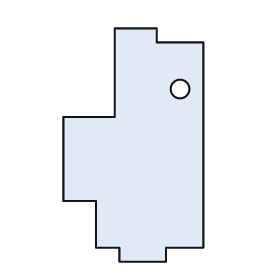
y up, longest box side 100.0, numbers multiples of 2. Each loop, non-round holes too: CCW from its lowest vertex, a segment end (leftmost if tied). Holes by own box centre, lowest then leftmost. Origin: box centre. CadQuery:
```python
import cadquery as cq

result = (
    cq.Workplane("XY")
    .moveTo(-6.0, -50.0)
    .lineTo(14.0, -50.0)
    .lineTo(14.0, -44.0)
    .lineTo(30.0, -44.0)
    .lineTo(30.0, 44.0)
    .lineTo(10.0, 44.0)
    .lineTo(10.0, 50.0)
    .lineTo(-8.0, 50.0)
    .lineTo(-8.0, 12.0)
    .lineTo(-30.0, 12.0)
    .lineTo(-30.0, -24.0)
    .lineTo(-16.0, -24.0)
    .lineTo(-16.0, -44.0)
    .lineTo(-6.0, -44.0)
    .close()
    .moveTo(20.0, 24.0)
    .circle(4.0)
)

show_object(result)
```